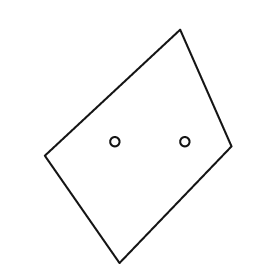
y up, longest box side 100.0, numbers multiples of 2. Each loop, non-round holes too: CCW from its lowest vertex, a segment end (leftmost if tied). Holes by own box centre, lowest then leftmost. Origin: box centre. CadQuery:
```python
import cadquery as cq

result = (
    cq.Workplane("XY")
    .moveTo(-8.0, -50.0)
    .lineTo(40.0, 0.0)
    .lineTo(18.0, 50.0)
    .lineTo(-40.0, -4.0)
    .close()
    .moveTo(-10.0, 2.0)
    .circle(2.0)
    .moveTo(20.0, 2.0)
    .circle(2.0)
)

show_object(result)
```